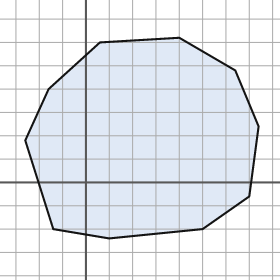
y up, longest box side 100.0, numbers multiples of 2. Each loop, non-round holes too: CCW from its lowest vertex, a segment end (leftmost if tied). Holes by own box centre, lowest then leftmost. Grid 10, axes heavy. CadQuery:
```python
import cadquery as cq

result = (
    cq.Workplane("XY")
    .moveTo(10.0, -24.0)
    .lineTo(50.0, -20.0)
    .lineTo(70.0, -6.0)
    .lineTo(74.0, 24.0)
    .lineTo(64.0, 48.0)
    .lineTo(40.0, 62.0)
    .lineTo(6.0, 60.0)
    .lineTo(-16.0, 40.0)
    .lineTo(-26.0, 18.0)
    .lineTo(-14.0, -20.0)
    .close()
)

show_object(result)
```